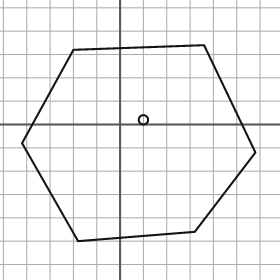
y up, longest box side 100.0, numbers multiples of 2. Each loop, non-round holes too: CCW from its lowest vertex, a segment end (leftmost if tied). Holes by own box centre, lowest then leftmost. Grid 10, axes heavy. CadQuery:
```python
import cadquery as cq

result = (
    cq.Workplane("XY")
    .moveTo(-18.0, -50.0)
    .lineTo(32.0, -46.0)
    .lineTo(58.0, -12.0)
    .lineTo(36.0, 34.0)
    .lineTo(-20.0, 32.0)
    .lineTo(-42.0, -8.0)
    .close()
    .moveTo(10.0, 2.0)
    .circle(2.0)
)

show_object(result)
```